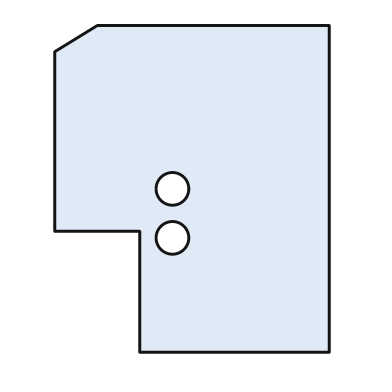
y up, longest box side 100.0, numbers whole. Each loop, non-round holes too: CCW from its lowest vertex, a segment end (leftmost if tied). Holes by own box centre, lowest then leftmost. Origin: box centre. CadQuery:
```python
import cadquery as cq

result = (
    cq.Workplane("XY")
    .moveTo(-16.0, -50.0)
    .lineTo(42.0, -50.0)
    .lineTo(42.0, 50.0)
    .lineTo(-29.0, 50.0)
    .lineTo(-42.0, 42.0)
    .lineTo(-42.0, -13.0)
    .lineTo(-16.0, -13.0)
    .close()
    .moveTo(-6.0, -15.0)
    .circle(5.0)
    .moveTo(-6.0, 0.0)
    .circle(5.0)
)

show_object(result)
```